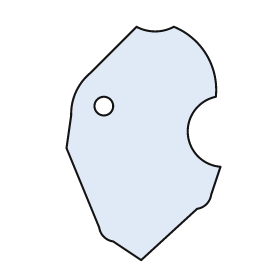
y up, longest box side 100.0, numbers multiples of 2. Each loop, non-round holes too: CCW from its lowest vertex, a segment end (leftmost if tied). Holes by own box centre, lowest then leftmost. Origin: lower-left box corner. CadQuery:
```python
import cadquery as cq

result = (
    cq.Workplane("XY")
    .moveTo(32.0, 0.0)
    .lineTo(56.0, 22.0)
    .threePointArc((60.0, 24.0), (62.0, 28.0))
    .lineTo(66.0, 40.0)
    .threePointArc((52.0, 54.0), (64.0, 70.0))
    .threePointArc((60.0, 88.0), (46.0, 100.0))
    .threePointArc((38.0, 98.0), (30.0, 100.0))
    .lineTo(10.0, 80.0)
    .threePointArc((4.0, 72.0), (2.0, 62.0))
    .lineTo(0.0, 48.0)
    .lineTo(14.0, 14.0)
    .threePointArc((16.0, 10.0), (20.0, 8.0))
    .close()
    .moveTo(16.0, 66.0)
    .circle(4.0)
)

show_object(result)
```